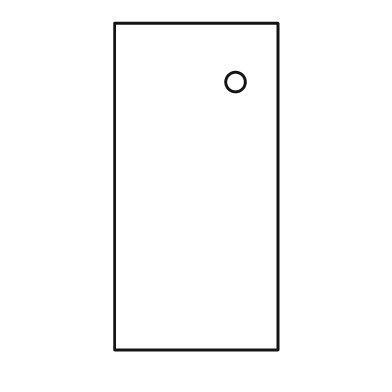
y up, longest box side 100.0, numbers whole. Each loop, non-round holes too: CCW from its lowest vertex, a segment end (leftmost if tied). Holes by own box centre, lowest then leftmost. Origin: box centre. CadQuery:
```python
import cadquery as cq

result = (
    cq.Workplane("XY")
    .moveTo(-25.0, -50.0)
    .lineTo(25.0, -50.0)
    .lineTo(25.0, 50.0)
    .lineTo(-25.0, 50.0)
    .close()
    .moveTo(12.0, 32.0)
    .circle(3.0)
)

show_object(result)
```